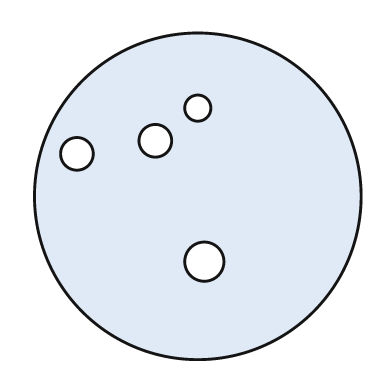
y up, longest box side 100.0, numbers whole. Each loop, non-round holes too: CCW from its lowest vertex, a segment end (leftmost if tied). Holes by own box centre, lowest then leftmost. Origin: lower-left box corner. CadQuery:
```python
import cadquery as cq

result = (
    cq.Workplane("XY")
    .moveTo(50.0, 50.0)
    .circle(50.0)
    .moveTo(52.0, 30.0)
    .circle(6.0)
    .moveTo(13.0, 63.0)
    .circle(5.0)
    .moveTo(37.0, 67.0)
    .circle(5.0)
    .moveTo(50.0, 77.0)
    .circle(4.0)
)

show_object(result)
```